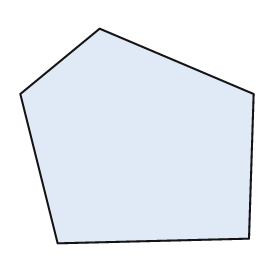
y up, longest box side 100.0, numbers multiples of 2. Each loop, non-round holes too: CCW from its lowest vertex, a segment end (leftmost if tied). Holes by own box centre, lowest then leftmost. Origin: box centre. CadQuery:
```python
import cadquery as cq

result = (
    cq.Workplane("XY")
    .moveTo(-34.0, -46.0)
    .lineTo(48.0, -44.0)
    .lineTo(50.0, 18.0)
    .lineTo(-16.0, 46.0)
    .lineTo(-50.0, 18.0)
    .close()
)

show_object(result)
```